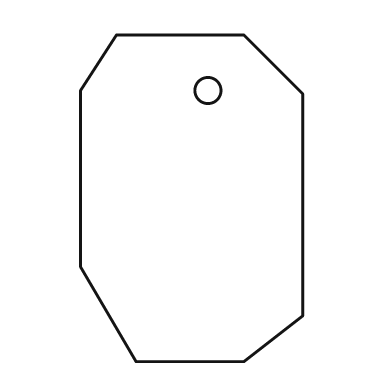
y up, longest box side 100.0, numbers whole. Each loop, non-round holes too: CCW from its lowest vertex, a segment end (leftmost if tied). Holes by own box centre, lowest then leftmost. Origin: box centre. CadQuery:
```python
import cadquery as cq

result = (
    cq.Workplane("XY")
    .moveTo(-17.0, -50.0)
    .lineTo(16.0, -50.0)
    .lineTo(34.0, -36.0)
    .lineTo(34.0, 32.0)
    .lineTo(16.0, 50.0)
    .lineTo(-23.0, 50.0)
    .lineTo(-34.0, 33.0)
    .lineTo(-34.0, -21.0)
    .close()
    .moveTo(5.0, 33.0)
    .circle(4.0)
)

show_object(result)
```